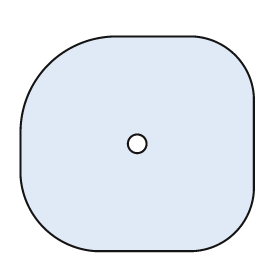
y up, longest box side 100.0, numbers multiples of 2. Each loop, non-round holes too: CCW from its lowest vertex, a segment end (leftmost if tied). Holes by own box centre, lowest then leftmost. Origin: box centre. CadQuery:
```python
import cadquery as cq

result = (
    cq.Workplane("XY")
    .moveTo(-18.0, -46.0)
    .lineTo(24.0, -46.0)
    .threePointArc((42.0, -38.0), (50.0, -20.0))
    .lineTo(50.0, 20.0)
    .threePointArc((42.0, 38.0), (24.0, 46.0))
    .lineTo(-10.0, 46.0)
    .threePointArc((-38.0, 34.0), (-50.0, 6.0))
    .lineTo(-50.0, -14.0)
    .threePointArc((-40.0, -36.0), (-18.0, -46.0))
    .close()
    .moveTo(0.0, 0.0)
    .circle(4.0)
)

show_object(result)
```